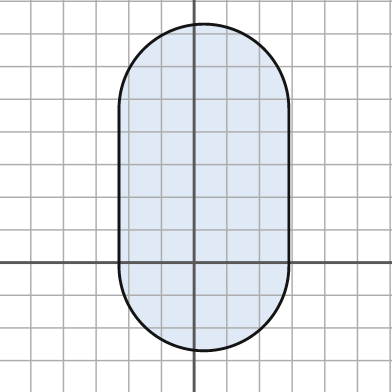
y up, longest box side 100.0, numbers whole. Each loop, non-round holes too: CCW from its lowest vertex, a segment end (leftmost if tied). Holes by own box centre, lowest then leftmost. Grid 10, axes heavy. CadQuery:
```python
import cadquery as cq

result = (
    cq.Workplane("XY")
    .moveTo(-23.0, -1.0)
    .threePointArc((3.0, -27.0), (29.0, -1.0))
    .lineTo(29.0, 47.0)
    .threePointArc((3.0, 73.0), (-23.0, 47.0))
    .close()
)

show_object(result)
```